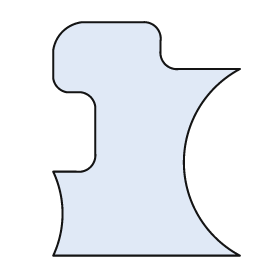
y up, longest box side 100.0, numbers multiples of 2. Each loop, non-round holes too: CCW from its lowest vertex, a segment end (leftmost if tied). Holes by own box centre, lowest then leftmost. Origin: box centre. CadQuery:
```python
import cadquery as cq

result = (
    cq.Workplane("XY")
    .moveTo(-40.0, -50.0)
    .lineTo(40.0, -50.0)
    .threePointArc((16.0, -10.0), (40.0, 30.0))
    .lineTo(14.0, 30.0)
    .threePointArc((8.0, 32.0), (6.0, 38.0))
    .lineTo(6.0, 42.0)
    .threePointArc((4.0, 48.0), (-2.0, 50.0))
    .lineTo(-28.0, 50.0)
    .threePointArc((-36.0, 46.0), (-40.0, 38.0))
    .lineTo(-40.0, 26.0)
    .threePointArc((-38.0, 22.0), (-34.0, 20.0))
    .lineTo(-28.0, 20.0)
    .threePointArc((-24.0, 18.0), (-22.0, 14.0))
    .lineTo(-22.0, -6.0)
    .threePointArc((-24.0, -12.0), (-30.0, -14.0))
    .lineTo(-40.0, -14.0)
    .threePointArc((-36.0, -32.0), (-40.0, -50.0))
    .close()
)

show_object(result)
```